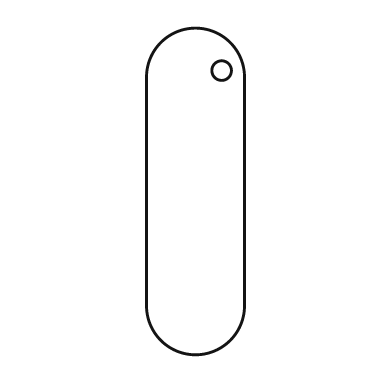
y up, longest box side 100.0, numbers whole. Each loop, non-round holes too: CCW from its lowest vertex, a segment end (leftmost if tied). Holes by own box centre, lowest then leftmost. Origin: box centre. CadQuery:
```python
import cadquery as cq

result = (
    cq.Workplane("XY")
    .moveTo(-15.0, -35.0)
    .threePointArc((0.0, -50.0), (15.0, -35.0))
    .lineTo(15.0, 35.0)
    .threePointArc((0.0, 50.0), (-15.0, 35.0))
    .close()
    .moveTo(8.0, 37.0)
    .circle(3.0)
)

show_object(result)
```